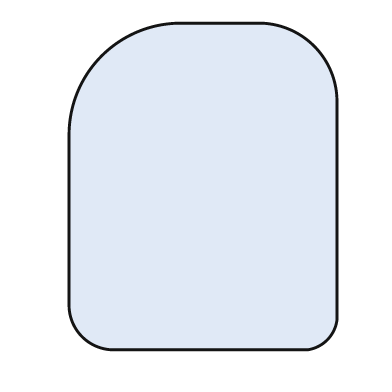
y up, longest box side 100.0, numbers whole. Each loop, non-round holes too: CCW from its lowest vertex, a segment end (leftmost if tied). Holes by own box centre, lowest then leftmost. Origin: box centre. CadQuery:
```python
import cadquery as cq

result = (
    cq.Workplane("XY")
    .moveTo(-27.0, -50.0)
    .lineTo(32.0, -50.0)
    .threePointArc((38.0, -47.0), (41.0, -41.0))
    .lineTo(41.0, 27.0)
    .threePointArc((34.0, 43.0), (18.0, 50.0))
    .lineTo(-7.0, 50.0)
    .threePointArc((-31.0, 40.0), (-41.0, 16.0))
    .lineTo(-41.0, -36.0)
    .threePointArc((-37.0, -46.0), (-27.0, -50.0))
    .close()
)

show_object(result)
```